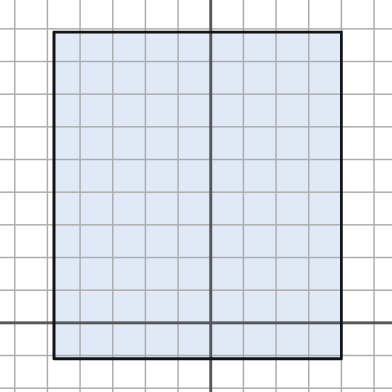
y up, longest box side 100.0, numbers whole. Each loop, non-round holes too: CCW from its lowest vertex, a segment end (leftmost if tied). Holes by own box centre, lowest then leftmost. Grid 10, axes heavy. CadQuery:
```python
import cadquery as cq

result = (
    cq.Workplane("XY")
    .moveTo(-48.0, -11.0)
    .lineTo(40.0, -11.0)
    .lineTo(40.0, 89.0)
    .lineTo(-48.0, 89.0)
    .close()
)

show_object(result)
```